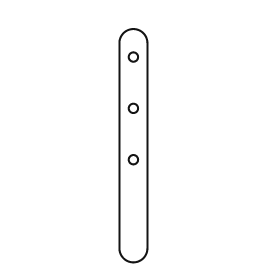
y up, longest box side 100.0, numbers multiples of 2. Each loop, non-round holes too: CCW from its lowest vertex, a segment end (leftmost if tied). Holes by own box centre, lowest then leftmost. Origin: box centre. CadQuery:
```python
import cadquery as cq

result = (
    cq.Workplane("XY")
    .moveTo(-6.0, -44.0)
    .threePointArc((0.0, -50.0), (6.0, -44.0))
    .lineTo(6.0, 44.0)
    .threePointArc((0.0, 50.0), (-6.0, 44.0))
    .close()
    .moveTo(0.0, -6.0)
    .circle(2.0)
    .moveTo(0.0, 16.0)
    .circle(2.0)
    .moveTo(0.0, 38.0)
    .circle(2.0)
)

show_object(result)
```